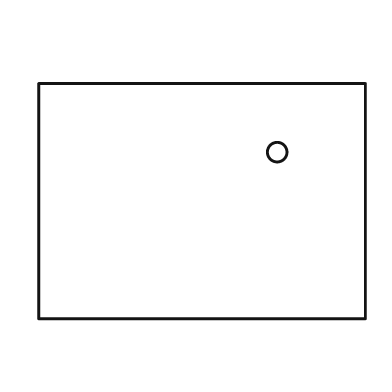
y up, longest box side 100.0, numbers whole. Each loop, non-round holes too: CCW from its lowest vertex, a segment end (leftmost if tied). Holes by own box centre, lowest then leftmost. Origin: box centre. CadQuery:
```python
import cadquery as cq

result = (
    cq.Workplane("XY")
    .moveTo(-50.0, -36.0)
    .lineTo(50.0, -36.0)
    .lineTo(50.0, 36.0)
    .lineTo(-50.0, 36.0)
    .close()
    .moveTo(23.0, 15.0)
    .circle(3.0)
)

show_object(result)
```